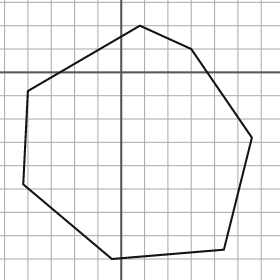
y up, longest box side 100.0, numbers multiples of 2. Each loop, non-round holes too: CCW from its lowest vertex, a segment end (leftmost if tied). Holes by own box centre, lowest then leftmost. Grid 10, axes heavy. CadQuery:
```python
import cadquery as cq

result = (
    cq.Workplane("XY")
    .moveTo(-4.0, -80.0)
    .lineTo(44.0, -76.0)
    .lineTo(56.0, -28.0)
    .lineTo(30.0, 10.0)
    .lineTo(8.0, 20.0)
    .lineTo(-40.0, -8.0)
    .lineTo(-42.0, -48.0)
    .close()
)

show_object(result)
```